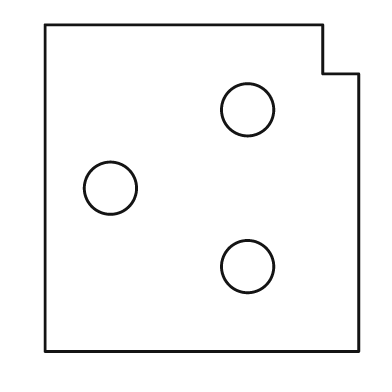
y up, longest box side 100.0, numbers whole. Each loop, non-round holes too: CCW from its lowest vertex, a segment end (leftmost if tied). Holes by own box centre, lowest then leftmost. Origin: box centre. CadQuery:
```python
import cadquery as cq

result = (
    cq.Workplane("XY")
    .moveTo(-48.0, -50.0)
    .lineTo(48.0, -50.0)
    .lineTo(48.0, 35.0)
    .lineTo(37.0, 35.0)
    .lineTo(37.0, 50.0)
    .lineTo(-48.0, 50.0)
    .close()
    .moveTo(14.0, -24.0)
    .circle(8.0)
    .moveTo(-28.0, 0.0)
    .circle(8.0)
    .moveTo(14.0, 24.0)
    .circle(8.0)
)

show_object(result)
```